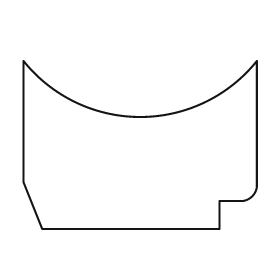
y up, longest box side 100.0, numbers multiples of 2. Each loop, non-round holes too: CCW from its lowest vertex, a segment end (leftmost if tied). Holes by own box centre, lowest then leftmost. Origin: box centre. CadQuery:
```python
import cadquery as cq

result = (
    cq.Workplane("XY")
    .moveTo(-42.0, -36.0)
    .lineTo(34.0, -36.0)
    .lineTo(34.0, -24.0)
    .lineTo(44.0, -24.0)
    .threePointArc((48.0, -22.0), (50.0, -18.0))
    .lineTo(50.0, 36.0)
    .threePointArc((0.0, 12.0), (-50.0, 36.0))
    .lineTo(-50.0, -16.0)
    .close()
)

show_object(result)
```